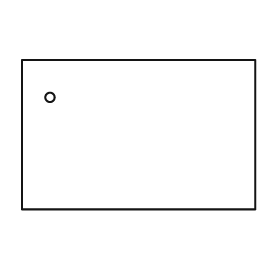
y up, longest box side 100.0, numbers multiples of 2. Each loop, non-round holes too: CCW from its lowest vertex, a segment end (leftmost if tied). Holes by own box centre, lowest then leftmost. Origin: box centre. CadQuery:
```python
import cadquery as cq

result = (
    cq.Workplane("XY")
    .moveTo(-50.0, -32.0)
    .lineTo(50.0, -32.0)
    .lineTo(50.0, 32.0)
    .lineTo(-50.0, 32.0)
    .close()
    .moveTo(-38.0, 16.0)
    .circle(2.0)
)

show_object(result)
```